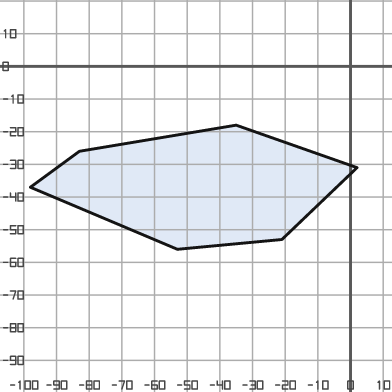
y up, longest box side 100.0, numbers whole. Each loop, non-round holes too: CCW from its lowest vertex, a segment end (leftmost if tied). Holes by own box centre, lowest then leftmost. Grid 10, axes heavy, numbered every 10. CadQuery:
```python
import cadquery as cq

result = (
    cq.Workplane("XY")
    .moveTo(-53.0, -56.0)
    .lineTo(-21.0, -53.0)
    .lineTo(2.0, -31.0)
    .lineTo(-35.0, -18.0)
    .lineTo(-83.0, -26.0)
    .lineTo(-98.0, -37.0)
    .close()
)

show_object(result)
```